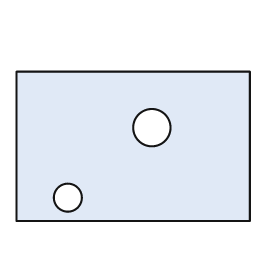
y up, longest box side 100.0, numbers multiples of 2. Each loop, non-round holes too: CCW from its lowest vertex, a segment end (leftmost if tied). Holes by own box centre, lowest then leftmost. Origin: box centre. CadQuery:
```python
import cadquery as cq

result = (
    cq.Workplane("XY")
    .moveTo(-50.0, -32.0)
    .lineTo(50.0, -32.0)
    .lineTo(50.0, 32.0)
    .lineTo(-50.0, 32.0)
    .close()
    .moveTo(-28.0, -22.0)
    .circle(6.0)
    .moveTo(8.0, 8.0)
    .circle(8.0)
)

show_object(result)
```